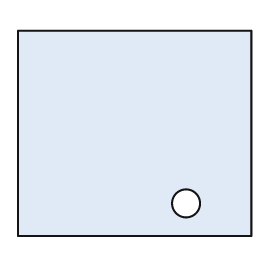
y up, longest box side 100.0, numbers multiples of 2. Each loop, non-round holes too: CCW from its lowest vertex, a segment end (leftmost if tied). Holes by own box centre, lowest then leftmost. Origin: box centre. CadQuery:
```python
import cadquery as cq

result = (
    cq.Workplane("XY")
    .moveTo(-50.0, -44.0)
    .lineTo(50.0, -44.0)
    .lineTo(50.0, 44.0)
    .lineTo(-50.0, 44.0)
    .close()
    .moveTo(22.0, -30.0)
    .circle(6.0)
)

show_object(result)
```